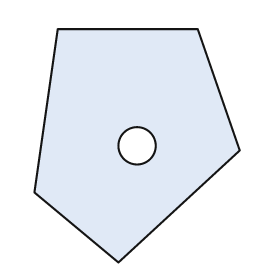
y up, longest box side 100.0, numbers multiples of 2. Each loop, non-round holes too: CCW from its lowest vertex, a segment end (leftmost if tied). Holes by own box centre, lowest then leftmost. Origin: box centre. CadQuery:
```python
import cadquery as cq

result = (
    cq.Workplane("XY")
    .moveTo(-8.0, -50.0)
    .lineTo(44.0, -2.0)
    .lineTo(26.0, 50.0)
    .lineTo(-34.0, 50.0)
    .lineTo(-44.0, -20.0)
    .close()
    .moveTo(0.0, 0.0)
    .circle(8.0)
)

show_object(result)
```